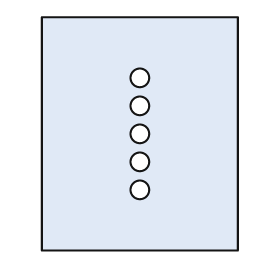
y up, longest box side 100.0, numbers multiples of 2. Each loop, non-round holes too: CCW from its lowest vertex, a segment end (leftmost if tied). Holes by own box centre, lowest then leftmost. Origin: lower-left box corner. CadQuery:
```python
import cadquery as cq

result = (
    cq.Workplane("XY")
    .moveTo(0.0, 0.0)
    .lineTo(84.0, 0.0)
    .lineTo(84.0, 100.0)
    .lineTo(0.0, 100.0)
    .close()
    .moveTo(42.0, 26.0)
    .circle(4.0)
    .moveTo(42.0, 38.0)
    .circle(4.0)
    .moveTo(42.0, 50.0)
    .circle(4.0)
    .moveTo(42.0, 62.0)
    .circle(4.0)
    .moveTo(42.0, 74.0)
    .circle(4.0)
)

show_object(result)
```